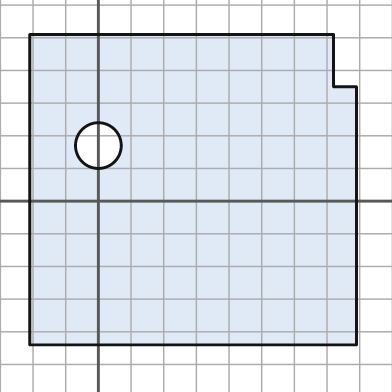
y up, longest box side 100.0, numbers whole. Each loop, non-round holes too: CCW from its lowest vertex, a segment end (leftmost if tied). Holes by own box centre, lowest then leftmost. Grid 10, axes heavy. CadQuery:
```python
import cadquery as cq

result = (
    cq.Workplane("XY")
    .moveTo(-21.0, -44.0)
    .lineTo(79.0, -44.0)
    .lineTo(79.0, 35.0)
    .lineTo(72.0, 35.0)
    .lineTo(72.0, 51.0)
    .lineTo(-21.0, 51.0)
    .close()
    .moveTo(0.0, 17.0)
    .circle(7.0)
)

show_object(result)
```